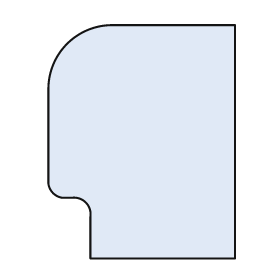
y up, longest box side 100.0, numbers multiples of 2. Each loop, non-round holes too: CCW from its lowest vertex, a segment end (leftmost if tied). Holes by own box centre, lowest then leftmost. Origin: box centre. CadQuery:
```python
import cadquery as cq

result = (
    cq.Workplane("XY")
    .moveTo(-22.0, -50.0)
    .lineTo(40.0, -50.0)
    .lineTo(40.0, 50.0)
    .lineTo(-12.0, 50.0)
    .threePointArc((-32.0, 42.0), (-40.0, 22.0))
    .lineTo(-40.0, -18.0)
    .threePointArc((-38.0, -22.0), (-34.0, -24.0))
    .lineTo(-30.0, -24.0)
    .threePointArc((-24.0, -26.0), (-22.0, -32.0))
    .close()
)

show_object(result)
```